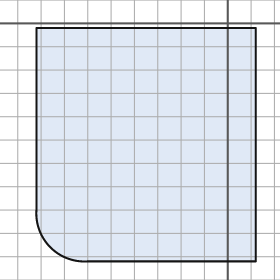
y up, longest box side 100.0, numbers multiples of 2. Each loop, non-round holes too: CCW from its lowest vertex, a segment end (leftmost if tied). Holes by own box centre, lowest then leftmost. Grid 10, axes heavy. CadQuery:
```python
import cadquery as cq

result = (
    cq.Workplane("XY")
    .moveTo(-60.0, -102.0)
    .lineTo(12.0, -102.0)
    .lineTo(12.0, -2.0)
    .lineTo(-82.0, -2.0)
    .lineTo(-82.0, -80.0)
    .threePointArc((-76.0, -96.0), (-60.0, -102.0))
    .close()
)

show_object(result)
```